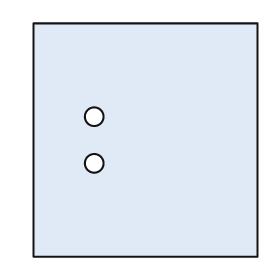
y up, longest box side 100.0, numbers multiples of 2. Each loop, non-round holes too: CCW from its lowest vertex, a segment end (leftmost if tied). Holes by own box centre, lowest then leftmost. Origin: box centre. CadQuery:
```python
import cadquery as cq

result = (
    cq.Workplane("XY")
    .moveTo(-48.0, -50.0)
    .lineTo(48.0, -50.0)
    .lineTo(48.0, 50.0)
    .lineTo(-48.0, 50.0)
    .close()
    .moveTo(-22.0, -10.0)
    .circle(4.0)
    .moveTo(-22.0, 10.0)
    .circle(4.0)
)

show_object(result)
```